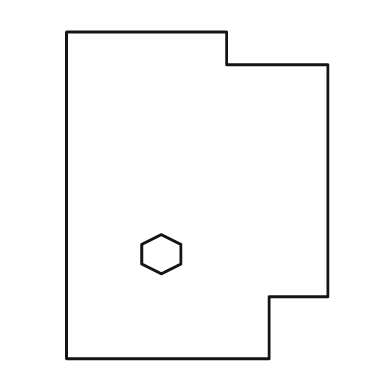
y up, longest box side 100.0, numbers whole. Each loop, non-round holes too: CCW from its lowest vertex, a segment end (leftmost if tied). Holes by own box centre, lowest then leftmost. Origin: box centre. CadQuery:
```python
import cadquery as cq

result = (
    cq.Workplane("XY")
    .moveTo(-40.0, -50.0)
    .lineTo(22.0, -50.0)
    .lineTo(22.0, -31.0)
    .lineTo(40.0, -31.0)
    .lineTo(40.0, 40.0)
    .lineTo(9.0, 40.0)
    .lineTo(9.0, 50.0)
    .lineTo(-40.0, 50.0)
    .close()
    .moveTo(-11.0, -24.0)
    .lineTo(-5.0, -21.0)
    .lineTo(-5.0, -15.0)
    .lineTo(-11.0, -12.0)
    .lineTo(-17.0, -15.0)
    .lineTo(-17.0, -21.0)
    .close()
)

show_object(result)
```